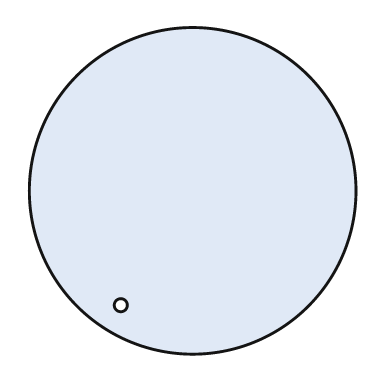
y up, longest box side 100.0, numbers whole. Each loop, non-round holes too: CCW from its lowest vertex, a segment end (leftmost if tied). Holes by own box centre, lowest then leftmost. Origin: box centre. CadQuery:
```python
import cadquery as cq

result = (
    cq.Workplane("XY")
    .moveTo(0.0, 0.0)
    .circle(50.0)
    .moveTo(-22.0, -35.0)
    .circle(2.0)
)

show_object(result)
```